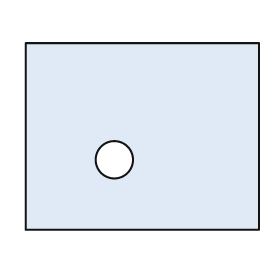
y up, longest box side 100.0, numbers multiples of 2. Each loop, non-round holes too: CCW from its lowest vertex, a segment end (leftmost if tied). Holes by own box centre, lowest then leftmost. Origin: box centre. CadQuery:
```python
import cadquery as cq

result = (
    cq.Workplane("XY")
    .moveTo(-50.0, -40.0)
    .lineTo(50.0, -40.0)
    .lineTo(50.0, 40.0)
    .lineTo(-50.0, 40.0)
    .close()
    .moveTo(-12.0, -10.0)
    .circle(8.0)
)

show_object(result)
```